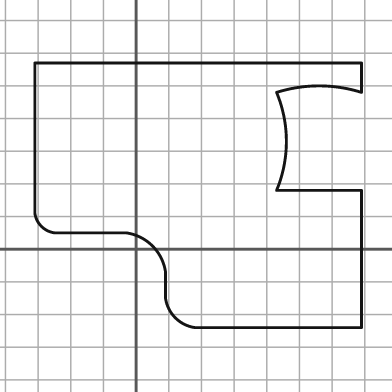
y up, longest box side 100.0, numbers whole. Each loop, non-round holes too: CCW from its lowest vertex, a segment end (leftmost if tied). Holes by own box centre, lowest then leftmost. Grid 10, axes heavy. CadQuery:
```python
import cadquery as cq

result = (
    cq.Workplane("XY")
    .moveTo(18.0, -24.0)
    .lineTo(69.0, -24.0)
    .lineTo(69.0, 18.0)
    .lineTo(43.0, 18.0)
    .threePointArc((46.0, 33.0), (43.0, 48.0))
    .threePointArc((56.0, 50.0), (69.0, 48.0))
    .lineTo(69.0, 57.0)
    .lineTo(-31.0, 57.0)
    .lineTo(-31.0, 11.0)
    .threePointArc((-29.0, 7.0), (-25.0, 5.0))
    .lineTo(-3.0, 5.0)
    .threePointArc((5.0, 1.0), (9.0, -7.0))
    .lineTo(9.0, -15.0)
    .threePointArc((12.0, -21.0), (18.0, -24.0))
    .close()
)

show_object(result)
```